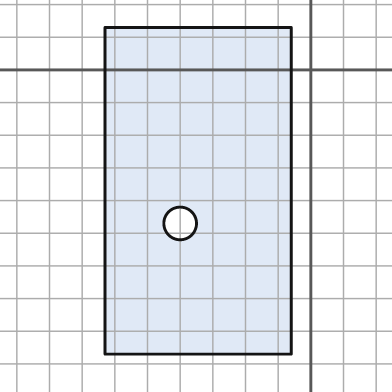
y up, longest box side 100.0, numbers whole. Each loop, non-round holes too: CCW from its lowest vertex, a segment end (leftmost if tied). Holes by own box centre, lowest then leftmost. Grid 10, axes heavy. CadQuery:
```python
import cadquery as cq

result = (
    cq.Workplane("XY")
    .moveTo(-63.0, -87.0)
    .lineTo(-6.0, -87.0)
    .lineTo(-6.0, 13.0)
    .lineTo(-63.0, 13.0)
    .close()
    .moveTo(-40.0, -47.0)
    .circle(5.0)
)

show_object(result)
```